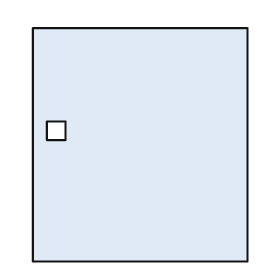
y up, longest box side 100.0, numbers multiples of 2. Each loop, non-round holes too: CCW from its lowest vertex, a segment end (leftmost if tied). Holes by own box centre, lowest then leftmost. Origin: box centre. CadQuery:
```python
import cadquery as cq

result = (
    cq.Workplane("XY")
    .moveTo(-46.0, -50.0)
    .lineTo(46.0, -50.0)
    .lineTo(46.0, 50.0)
    .lineTo(-46.0, 50.0)
    .close()
    .moveTo(-40.0, 2.0)
    .lineTo(-32.0, 2.0)
    .lineTo(-32.0, 10.0)
    .lineTo(-40.0, 10.0)
    .close()
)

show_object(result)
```